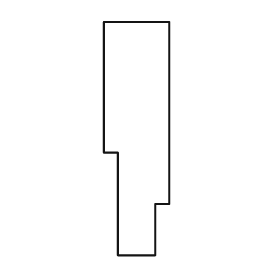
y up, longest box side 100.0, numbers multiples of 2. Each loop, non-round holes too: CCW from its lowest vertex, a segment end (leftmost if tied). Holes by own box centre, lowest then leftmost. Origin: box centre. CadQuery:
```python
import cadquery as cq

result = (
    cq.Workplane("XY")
    .moveTo(-8.0, -50.0)
    .lineTo(8.0, -50.0)
    .lineTo(8.0, -28.0)
    .lineTo(14.0, -28.0)
    .lineTo(14.0, 50.0)
    .lineTo(-14.0, 50.0)
    .lineTo(-14.0, -6.0)
    .lineTo(-8.0, -6.0)
    .close()
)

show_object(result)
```